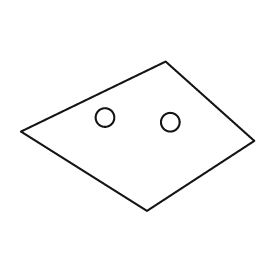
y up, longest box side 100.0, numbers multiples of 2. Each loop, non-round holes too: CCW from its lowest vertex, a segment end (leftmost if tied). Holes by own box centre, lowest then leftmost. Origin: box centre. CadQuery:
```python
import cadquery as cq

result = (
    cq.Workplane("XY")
    .moveTo(4.0, -32.0)
    .lineTo(50.0, -2.0)
    .lineTo(12.0, 32.0)
    .lineTo(-50.0, 2.0)
    .close()
    .moveTo(14.0, 6.0)
    .circle(4.0)
    .moveTo(-14.0, 8.0)
    .circle(4.0)
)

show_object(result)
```